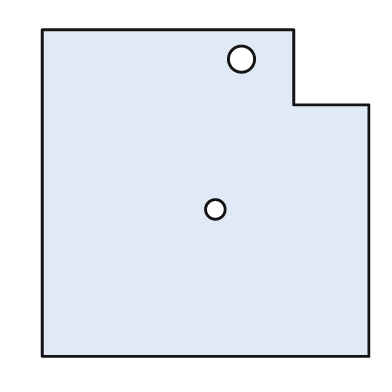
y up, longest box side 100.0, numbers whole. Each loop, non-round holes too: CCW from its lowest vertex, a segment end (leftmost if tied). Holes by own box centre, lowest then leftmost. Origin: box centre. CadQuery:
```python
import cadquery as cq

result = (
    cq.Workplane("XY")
    .moveTo(-50.0, -50.0)
    .lineTo(50.0, -50.0)
    .lineTo(50.0, 27.0)
    .lineTo(27.0, 27.0)
    .lineTo(27.0, 50.0)
    .lineTo(-50.0, 50.0)
    .close()
    .moveTo(3.0, -5.0)
    .circle(3.0)
    .moveTo(11.0, 41.0)
    .circle(4.0)
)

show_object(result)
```